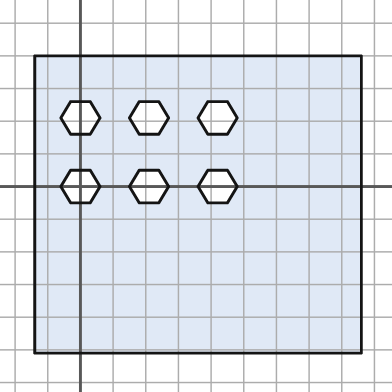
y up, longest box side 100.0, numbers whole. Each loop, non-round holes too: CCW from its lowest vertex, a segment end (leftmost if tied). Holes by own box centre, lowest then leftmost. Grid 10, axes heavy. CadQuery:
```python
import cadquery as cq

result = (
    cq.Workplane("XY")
    .moveTo(-14.0, -51.0)
    .lineTo(86.0, -51.0)
    .lineTo(86.0, 40.0)
    .lineTo(-14.0, 40.0)
    .close()
    .moveTo(-3.0, -5.0)
    .lineTo(3.0, -5.0)
    .lineTo(6.0, 0.0)
    .lineTo(3.0, 5.0)
    .lineTo(-3.0, 5.0)
    .lineTo(-6.0, 0.0)
    .close()
    .moveTo(18.0, -5.0)
    .lineTo(24.0, -5.0)
    .lineTo(27.0, 0.0)
    .lineTo(24.0, 5.0)
    .lineTo(18.0, 5.0)
    .lineTo(15.0, 0.0)
    .close()
    .moveTo(39.0, -5.0)
    .lineTo(45.0, -5.0)
    .lineTo(48.0, 0.0)
    .lineTo(45.0, 5.0)
    .lineTo(39.0, 5.0)
    .lineTo(36.0, 0.0)
    .close()
    .moveTo(-3.0, 16.0)
    .lineTo(3.0, 16.0)
    .lineTo(6.0, 21.0)
    .lineTo(3.0, 26.0)
    .lineTo(-3.0, 26.0)
    .lineTo(-6.0, 21.0)
    .close()
    .moveTo(18.0, 16.0)
    .lineTo(24.0, 16.0)
    .lineTo(27.0, 21.0)
    .lineTo(24.0, 26.0)
    .lineTo(18.0, 26.0)
    .lineTo(15.0, 21.0)
    .close()
    .moveTo(39.0, 16.0)
    .lineTo(45.0, 16.0)
    .lineTo(48.0, 21.0)
    .lineTo(45.0, 26.0)
    .lineTo(39.0, 26.0)
    .lineTo(36.0, 21.0)
    .close()
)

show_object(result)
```